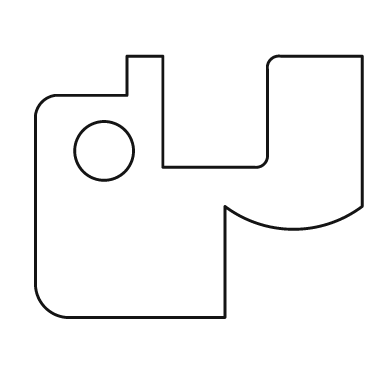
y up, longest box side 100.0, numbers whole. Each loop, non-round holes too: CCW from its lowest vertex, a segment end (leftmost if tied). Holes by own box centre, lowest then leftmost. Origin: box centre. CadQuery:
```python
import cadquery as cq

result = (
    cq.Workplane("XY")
    .moveTo(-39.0, -40.0)
    .lineTo(8.0, -40.0)
    .lineTo(8.0, -6.0)
    .threePointArc((29.0, -13.0), (50.0, -6.0))
    .lineTo(50.0, 40.0)
    .lineTo(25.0, 40.0)
    .threePointArc((22.0, 39.0), (21.0, 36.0))
    .lineTo(21.0, 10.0)
    .threePointArc((20.0, 7.0), (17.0, 6.0))
    .lineTo(-11.0, 6.0)
    .lineTo(-11.0, 40.0)
    .lineTo(-22.0, 40.0)
    .lineTo(-22.0, 28.0)
    .lineTo(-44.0, 28.0)
    .threePointArc((-48.0, 26.0), (-50.0, 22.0))
    .lineTo(-50.0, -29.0)
    .threePointArc((-47.0, -37.0), (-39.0, -40.0))
    .close()
    .moveTo(-29.0, 11.0)
    .circle(9.0)
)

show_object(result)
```